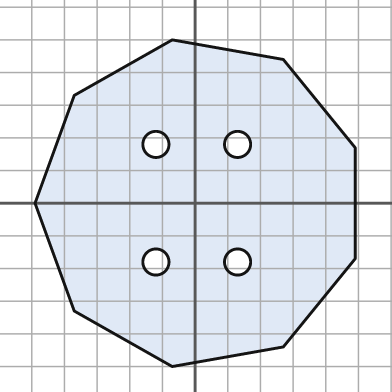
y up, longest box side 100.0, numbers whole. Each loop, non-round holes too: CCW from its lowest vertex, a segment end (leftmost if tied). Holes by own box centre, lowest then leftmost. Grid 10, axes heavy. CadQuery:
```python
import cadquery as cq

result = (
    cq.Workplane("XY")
    .moveTo(-7.0, -50.0)
    .lineTo(27.0, -44.0)
    .lineTo(49.0, -17.0)
    .lineTo(49.0, 17.0)
    .lineTo(27.0, 44.0)
    .lineTo(-7.0, 50.0)
    .lineTo(-37.0, 33.0)
    .lineTo(-49.0, 0.0)
    .lineTo(-37.0, -33.0)
    .close()
    .moveTo(-12.0, -18.0)
    .circle(4.0)
    .moveTo(13.0, -18.0)
    .circle(4.0)
    .moveTo(-12.0, 18.0)
    .circle(4.0)
    .moveTo(13.0, 18.0)
    .circle(4.0)
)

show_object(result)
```